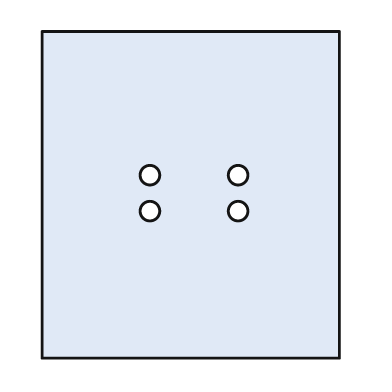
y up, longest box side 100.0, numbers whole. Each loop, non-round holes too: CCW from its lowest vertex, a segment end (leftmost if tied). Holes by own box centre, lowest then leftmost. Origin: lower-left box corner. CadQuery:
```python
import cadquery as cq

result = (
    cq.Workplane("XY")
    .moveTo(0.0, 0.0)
    .lineTo(91.0, 0.0)
    .lineTo(91.0, 100.0)
    .lineTo(0.0, 100.0)
    .close()
    .moveTo(33.0, 45.0)
    .circle(3.0)
    .moveTo(60.0, 45.0)
    .circle(3.0)
    .moveTo(33.0, 56.0)
    .circle(3.0)
    .moveTo(60.0, 56.0)
    .circle(3.0)
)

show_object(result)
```